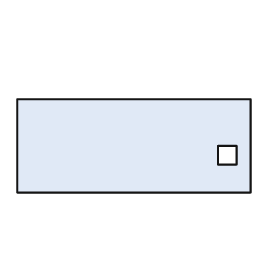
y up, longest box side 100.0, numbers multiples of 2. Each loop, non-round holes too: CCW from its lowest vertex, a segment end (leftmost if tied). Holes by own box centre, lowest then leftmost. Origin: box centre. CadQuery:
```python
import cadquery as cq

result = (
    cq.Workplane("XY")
    .moveTo(-50.0, -20.0)
    .lineTo(50.0, -20.0)
    .lineTo(50.0, 20.0)
    .lineTo(-50.0, 20.0)
    .close()
    .moveTo(36.0, -8.0)
    .lineTo(44.0, -8.0)
    .lineTo(44.0, 0.0)
    .lineTo(36.0, 0.0)
    .close()
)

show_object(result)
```